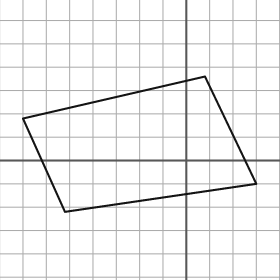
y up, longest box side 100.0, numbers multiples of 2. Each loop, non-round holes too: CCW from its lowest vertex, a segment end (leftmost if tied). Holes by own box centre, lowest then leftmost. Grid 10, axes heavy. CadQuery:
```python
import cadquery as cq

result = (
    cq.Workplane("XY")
    .moveTo(-52.0, -22.0)
    .lineTo(30.0, -10.0)
    .lineTo(8.0, 36.0)
    .lineTo(-70.0, 18.0)
    .close()
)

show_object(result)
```